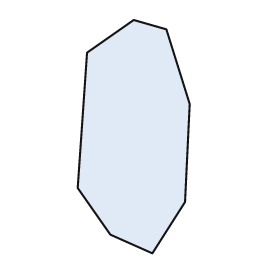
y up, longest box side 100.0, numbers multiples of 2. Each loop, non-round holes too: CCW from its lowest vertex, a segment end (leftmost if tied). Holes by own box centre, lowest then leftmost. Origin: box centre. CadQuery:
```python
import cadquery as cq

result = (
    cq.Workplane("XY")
    .moveTo(8.0, -50.0)
    .lineTo(22.0, -28.0)
    .lineTo(24.0, 14.0)
    .lineTo(14.0, 46.0)
    .lineTo(0.0, 50.0)
    .lineTo(-20.0, 36.0)
    .lineTo(-24.0, -22.0)
    .lineTo(-10.0, -42.0)
    .close()
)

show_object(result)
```